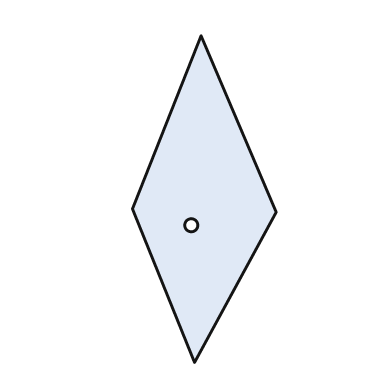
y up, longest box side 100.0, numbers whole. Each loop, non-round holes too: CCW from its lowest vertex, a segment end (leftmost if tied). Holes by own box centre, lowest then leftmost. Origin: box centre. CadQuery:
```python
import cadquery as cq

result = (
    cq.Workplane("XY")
    .moveTo(-3.0, -50.0)
    .lineTo(22.0, -4.0)
    .lineTo(-1.0, 50.0)
    .lineTo(-22.0, -3.0)
    .close()
    .moveTo(-4.0, -8.0)
    .circle(2.0)
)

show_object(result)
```